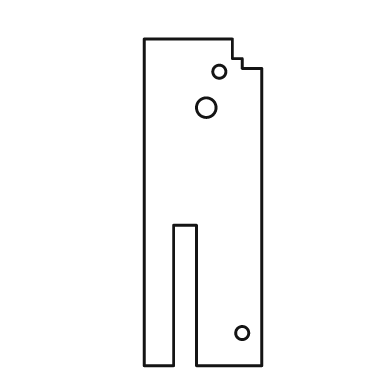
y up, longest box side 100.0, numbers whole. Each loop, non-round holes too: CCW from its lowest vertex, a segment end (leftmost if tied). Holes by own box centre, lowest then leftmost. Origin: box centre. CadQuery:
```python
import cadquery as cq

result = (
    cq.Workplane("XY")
    .moveTo(-18.0, -50.0)
    .lineTo(-9.0, -50.0)
    .lineTo(-9.0, -7.0)
    .lineTo(-2.0, -7.0)
    .lineTo(-2.0, -50.0)
    .lineTo(18.0, -50.0)
    .lineTo(18.0, 41.0)
    .lineTo(12.0, 41.0)
    .lineTo(12.0, 44.0)
    .lineTo(9.0, 44.0)
    .lineTo(9.0, 50.0)
    .lineTo(-18.0, 50.0)
    .close()
    .moveTo(12.0, -40.0)
    .circle(2.0)
    .moveTo(1.0, 29.0)
    .circle(3.0)
    .moveTo(5.0, 40.0)
    .circle(2.0)
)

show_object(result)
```